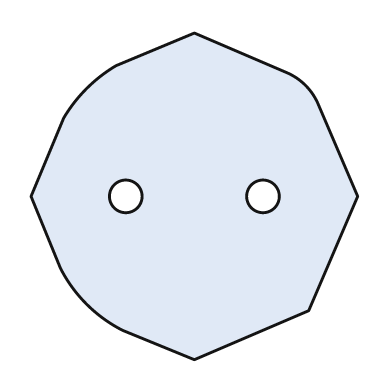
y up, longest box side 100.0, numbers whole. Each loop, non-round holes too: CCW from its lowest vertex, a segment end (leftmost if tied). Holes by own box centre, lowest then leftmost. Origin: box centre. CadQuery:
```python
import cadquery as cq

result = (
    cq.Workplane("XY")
    .moveTo(0.0, -50.0)
    .lineTo(35.0, -35.0)
    .lineTo(50.0, 0.0)
    .lineTo(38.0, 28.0)
    .threePointArc((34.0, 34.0), (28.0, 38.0))
    .lineTo(0.0, 50.0)
    .lineTo(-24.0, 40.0)
    .threePointArc((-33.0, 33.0), (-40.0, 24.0))
    .lineTo(-50.0, 0.0)
    .lineTo(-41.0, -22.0)
    .threePointArc((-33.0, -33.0), (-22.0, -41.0))
    .close()
    .moveTo(-21.0, 0.0)
    .circle(5.0)
    .moveTo(21.0, 0.0)
    .circle(5.0)
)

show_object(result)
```